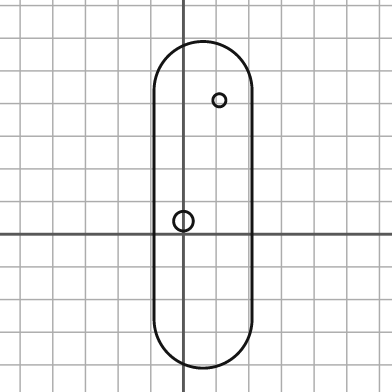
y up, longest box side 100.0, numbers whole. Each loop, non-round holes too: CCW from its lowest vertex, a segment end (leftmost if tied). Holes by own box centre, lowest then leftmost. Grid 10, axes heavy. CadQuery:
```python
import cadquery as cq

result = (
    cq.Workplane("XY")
    .moveTo(-9.0, -26.0)
    .threePointArc((6.0, -41.0), (21.0, -26.0))
    .lineTo(21.0, 44.0)
    .threePointArc((6.0, 59.0), (-9.0, 44.0))
    .close()
    .moveTo(0.0, 4.0)
    .circle(3.0)
    .moveTo(11.0, 41.0)
    .circle(2.0)
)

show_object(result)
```